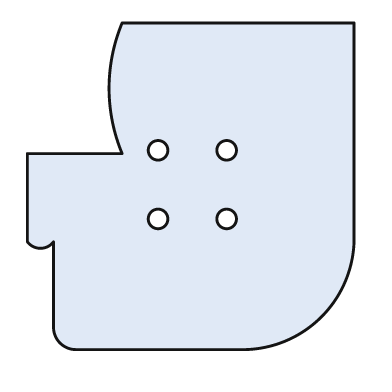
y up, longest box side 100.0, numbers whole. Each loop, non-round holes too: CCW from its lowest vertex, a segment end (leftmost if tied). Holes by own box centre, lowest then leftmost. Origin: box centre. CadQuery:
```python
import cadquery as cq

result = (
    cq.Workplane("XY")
    .moveTo(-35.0, -50.0)
    .lineTo(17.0, -50.0)
    .threePointArc((40.0, -40.0), (50.0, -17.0))
    .lineTo(50.0, 50.0)
    .lineTo(-21.0, 50.0)
    .threePointArc((-25.0, 30.0), (-21.0, 10.0))
    .lineTo(-50.0, 10.0)
    .lineTo(-50.0, -17.0)
    .threePointArc((-46.0, -19.0), (-42.0, -17.0))
    .lineTo(-42.0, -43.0)
    .threePointArc((-40.0, -48.0), (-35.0, -50.0))
    .close()
    .moveTo(-10.0, -10.0)
    .circle(3.0)
    .moveTo(11.0, -10.0)
    .circle(3.0)
    .moveTo(-10.0, 11.0)
    .circle(3.0)
    .moveTo(11.0, 11.0)
    .circle(3.0)
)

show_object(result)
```